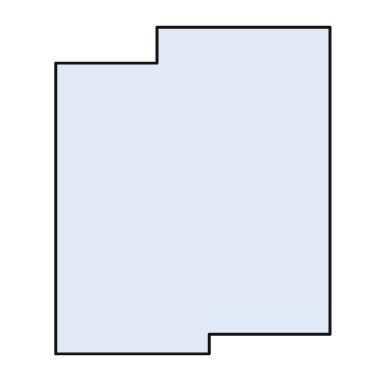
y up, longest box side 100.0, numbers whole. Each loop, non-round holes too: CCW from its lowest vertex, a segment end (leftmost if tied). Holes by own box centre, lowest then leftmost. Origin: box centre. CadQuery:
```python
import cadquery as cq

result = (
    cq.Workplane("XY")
    .moveTo(-42.0, -50.0)
    .lineTo(5.0, -50.0)
    .lineTo(5.0, -44.0)
    .lineTo(42.0, -44.0)
    .lineTo(42.0, 50.0)
    .lineTo(-11.0, 50.0)
    .lineTo(-11.0, 39.0)
    .lineTo(-42.0, 39.0)
    .close()
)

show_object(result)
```